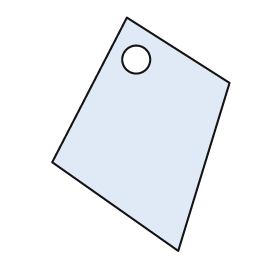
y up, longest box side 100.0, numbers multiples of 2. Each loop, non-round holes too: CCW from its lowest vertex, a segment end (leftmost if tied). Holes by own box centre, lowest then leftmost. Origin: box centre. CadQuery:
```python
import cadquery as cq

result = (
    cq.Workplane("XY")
    .moveTo(16.0, -50.0)
    .lineTo(38.0, 22.0)
    .lineTo(-6.0, 50.0)
    .lineTo(-38.0, -12.0)
    .close()
    .moveTo(-2.0, 32.0)
    .circle(6.0)
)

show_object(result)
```